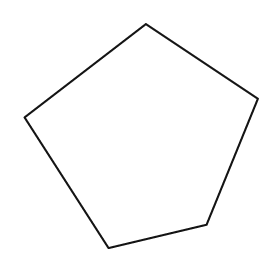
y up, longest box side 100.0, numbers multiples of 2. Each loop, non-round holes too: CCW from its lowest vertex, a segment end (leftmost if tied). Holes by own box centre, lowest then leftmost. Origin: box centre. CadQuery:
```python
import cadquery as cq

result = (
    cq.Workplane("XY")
    .moveTo(-14.0, -48.0)
    .lineTo(28.0, -38.0)
    .lineTo(50.0, 16.0)
    .lineTo(2.0, 48.0)
    .lineTo(-50.0, 8.0)
    .close()
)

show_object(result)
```